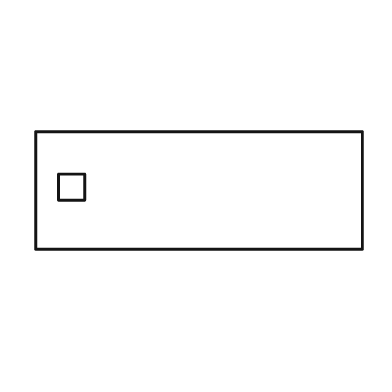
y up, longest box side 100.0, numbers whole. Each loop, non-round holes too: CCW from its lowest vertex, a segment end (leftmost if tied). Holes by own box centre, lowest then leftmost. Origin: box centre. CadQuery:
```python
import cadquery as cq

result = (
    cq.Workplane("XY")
    .moveTo(-50.0, -18.0)
    .lineTo(50.0, -18.0)
    .lineTo(50.0, 18.0)
    .lineTo(-50.0, 18.0)
    .close()
    .moveTo(-43.0, -3.0)
    .lineTo(-35.0, -3.0)
    .lineTo(-35.0, 5.0)
    .lineTo(-43.0, 5.0)
    .close()
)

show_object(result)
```